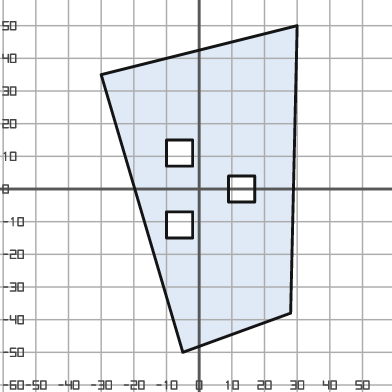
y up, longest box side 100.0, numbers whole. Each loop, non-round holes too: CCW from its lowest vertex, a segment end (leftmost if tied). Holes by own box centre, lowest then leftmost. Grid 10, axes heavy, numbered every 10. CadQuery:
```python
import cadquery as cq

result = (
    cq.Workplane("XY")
    .moveTo(-5.0, -50.0)
    .lineTo(28.0, -38.0)
    .lineTo(30.0, 50.0)
    .lineTo(-30.0, 35.0)
    .close()
    .moveTo(-10.0, -15.0)
    .lineTo(-2.0, -15.0)
    .lineTo(-2.0, -7.0)
    .lineTo(-10.0, -7.0)
    .close()
    .moveTo(9.0, -4.0)
    .lineTo(17.0, -4.0)
    .lineTo(17.0, 4.0)
    .lineTo(9.0, 4.0)
    .close()
    .moveTo(-10.0, 7.0)
    .lineTo(-2.0, 7.0)
    .lineTo(-2.0, 15.0)
    .lineTo(-10.0, 15.0)
    .close()
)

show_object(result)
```